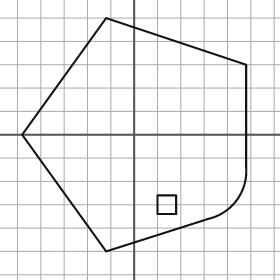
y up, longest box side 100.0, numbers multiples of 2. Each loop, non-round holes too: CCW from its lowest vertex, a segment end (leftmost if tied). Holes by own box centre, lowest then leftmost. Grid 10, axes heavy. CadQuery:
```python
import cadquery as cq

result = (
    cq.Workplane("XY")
    .moveTo(-12.0, -50.0)
    .lineTo(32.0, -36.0)
    .threePointArc((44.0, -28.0), (48.0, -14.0))
    .lineTo(48.0, 30.0)
    .lineTo(-12.0, 50.0)
    .lineTo(-48.0, 0.0)
    .close()
    .moveTo(10.0, -34.0)
    .lineTo(18.0, -34.0)
    .lineTo(18.0, -26.0)
    .lineTo(10.0, -26.0)
    .close()
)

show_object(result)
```